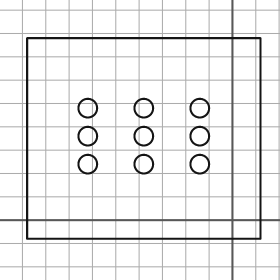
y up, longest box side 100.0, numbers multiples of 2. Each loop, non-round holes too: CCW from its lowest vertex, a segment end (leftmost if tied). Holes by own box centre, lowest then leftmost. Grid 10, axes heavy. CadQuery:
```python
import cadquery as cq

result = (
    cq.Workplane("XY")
    .moveTo(-88.0, -8.0)
    .lineTo(12.0, -8.0)
    .lineTo(12.0, 78.0)
    .lineTo(-88.0, 78.0)
    .close()
    .moveTo(-62.0, 24.0)
    .circle(4.0)
    .moveTo(-38.0, 24.0)
    .circle(4.0)
    .moveTo(-14.0, 24.0)
    .circle(4.0)
    .moveTo(-62.0, 36.0)
    .circle(4.0)
    .moveTo(-38.0, 36.0)
    .circle(4.0)
    .moveTo(-14.0, 36.0)
    .circle(4.0)
    .moveTo(-62.0, 48.0)
    .circle(4.0)
    .moveTo(-38.0, 48.0)
    .circle(4.0)
    .moveTo(-14.0, 48.0)
    .circle(4.0)
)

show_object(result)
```